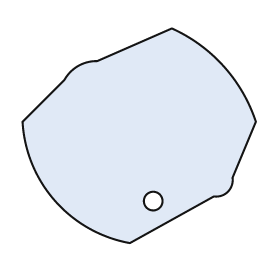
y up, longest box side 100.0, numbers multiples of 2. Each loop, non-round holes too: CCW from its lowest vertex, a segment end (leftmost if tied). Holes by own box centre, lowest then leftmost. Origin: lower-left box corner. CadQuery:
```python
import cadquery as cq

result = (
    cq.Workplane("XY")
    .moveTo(46.0, 0.0)
    .lineTo(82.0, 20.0)
    .threePointArc((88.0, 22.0), (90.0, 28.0))
    .lineTo(100.0, 52.0)
    .threePointArc((86.0, 76.0), (64.0, 92.0))
    .lineTo(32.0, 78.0)
    .threePointArc((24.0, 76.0), (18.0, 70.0))
    .lineTo(0.0, 52.0)
    .threePointArc((14.0, 18.0), (46.0, 0.0))
    .close()
    .moveTo(56.0, 18.0)
    .circle(4.0)
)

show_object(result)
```